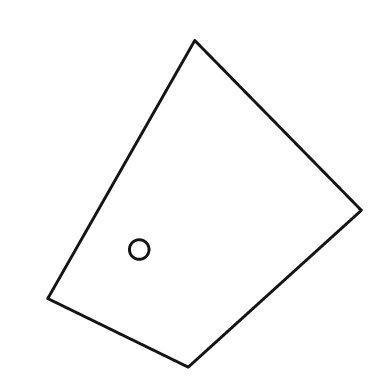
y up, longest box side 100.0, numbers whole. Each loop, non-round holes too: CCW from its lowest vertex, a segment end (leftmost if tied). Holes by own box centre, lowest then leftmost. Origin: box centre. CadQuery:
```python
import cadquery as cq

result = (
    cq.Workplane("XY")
    .moveTo(-5.0, -50.0)
    .lineTo(48.0, -2.0)
    .lineTo(-3.0, 50.0)
    .lineTo(-48.0, -29.0)
    .close()
    .moveTo(-20.0, -14.0)
    .circle(3.0)
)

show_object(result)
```